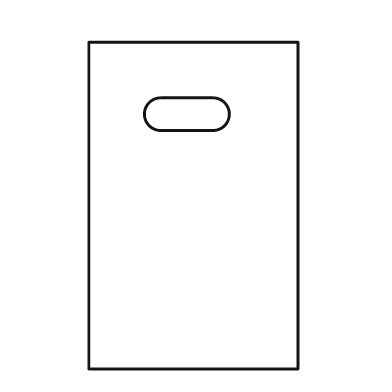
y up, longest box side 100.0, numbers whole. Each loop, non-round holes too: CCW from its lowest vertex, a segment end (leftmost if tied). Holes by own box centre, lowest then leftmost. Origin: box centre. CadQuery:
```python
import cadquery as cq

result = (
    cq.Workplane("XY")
    .moveTo(-32.0, -50.0)
    .lineTo(32.0, -50.0)
    .lineTo(32.0, 50.0)
    .lineTo(-32.0, 50.0)
    .close()
    .moveTo(-10.0, 23.0)
    .lineTo(6.0, 23.0)
    .threePointArc((11.0, 28.0), (6.0, 33.0))
    .lineTo(-10.0, 33.0)
    .threePointArc((-15.0, 28.0), (-10.0, 23.0))
    .close()
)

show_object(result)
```